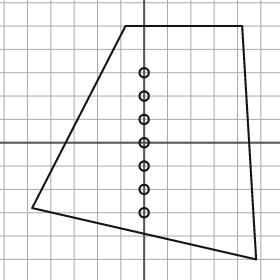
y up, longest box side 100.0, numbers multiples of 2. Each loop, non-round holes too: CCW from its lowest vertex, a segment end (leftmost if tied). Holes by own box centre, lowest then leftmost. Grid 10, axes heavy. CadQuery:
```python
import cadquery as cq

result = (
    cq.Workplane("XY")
    .moveTo(48.0, -50.0)
    .lineTo(42.0, 50.0)
    .lineTo(-8.0, 50.0)
    .lineTo(-48.0, -28.0)
    .close()
    .moveTo(0.0, -30.0)
    .circle(2.0)
    .moveTo(0.0, -20.0)
    .circle(2.0)
    .moveTo(0.0, -10.0)
    .circle(2.0)
    .moveTo(0.0, 0.0)
    .circle(2.0)
    .moveTo(0.0, 10.0)
    .circle(2.0)
    .moveTo(0.0, 20.0)
    .circle(2.0)
    .moveTo(0.0, 30.0)
    .circle(2.0)
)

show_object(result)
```